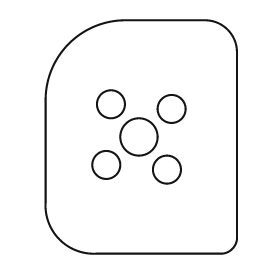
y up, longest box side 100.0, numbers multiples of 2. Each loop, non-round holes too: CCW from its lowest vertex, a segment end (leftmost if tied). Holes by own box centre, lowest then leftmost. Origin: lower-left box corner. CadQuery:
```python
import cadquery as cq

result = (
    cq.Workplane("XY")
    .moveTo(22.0, 0.0)
    .lineTo(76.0, 0.0)
    .threePointArc((80.0, 2.0), (82.0, 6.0))
    .lineTo(82.0, 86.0)
    .threePointArc((78.0, 96.0), (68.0, 100.0))
    .lineTo(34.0, 100.0)
    .threePointArc((10.0, 90.0), (0.0, 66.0))
    .lineTo(0.0, 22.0)
    .threePointArc((6.0, 6.0), (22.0, 0.0))
    .close()
    .moveTo(52.0, 36.0)
    .circle(6.0)
    .moveTo(26.0, 38.0)
    .circle(6.0)
    .moveTo(40.0, 50.0)
    .circle(8.0)
    .moveTo(54.0, 62.0)
    .circle(6.0)
    .moveTo(28.0, 64.0)
    .circle(6.0)
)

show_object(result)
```